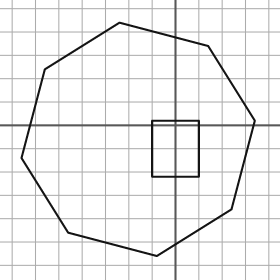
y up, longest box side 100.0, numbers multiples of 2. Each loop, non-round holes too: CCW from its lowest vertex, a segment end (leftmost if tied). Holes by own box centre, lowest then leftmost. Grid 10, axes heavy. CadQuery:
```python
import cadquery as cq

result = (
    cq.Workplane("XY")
    .moveTo(-8.0, -56.0)
    .lineTo(24.0, -36.0)
    .lineTo(34.0, 2.0)
    .lineTo(14.0, 34.0)
    .lineTo(-24.0, 44.0)
    .lineTo(-56.0, 24.0)
    .lineTo(-66.0, -14.0)
    .lineTo(-46.0, -46.0)
    .close()
    .moveTo(-10.0, -22.0)
    .lineTo(10.0, -22.0)
    .lineTo(10.0, 2.0)
    .lineTo(-10.0, 2.0)
    .close()
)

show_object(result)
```